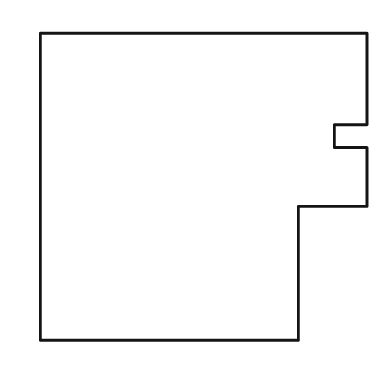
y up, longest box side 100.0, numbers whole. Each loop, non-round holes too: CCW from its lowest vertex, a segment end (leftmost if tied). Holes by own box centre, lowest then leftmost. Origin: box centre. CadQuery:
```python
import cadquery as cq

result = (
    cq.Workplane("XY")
    .moveTo(-50.0, -47.0)
    .lineTo(29.0, -47.0)
    .lineTo(29.0, -6.0)
    .lineTo(50.0, -6.0)
    .lineTo(50.0, 12.0)
    .lineTo(40.0, 12.0)
    .lineTo(40.0, 19.0)
    .lineTo(50.0, 19.0)
    .lineTo(50.0, 47.0)
    .lineTo(-50.0, 47.0)
    .close()
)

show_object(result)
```